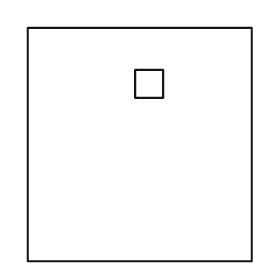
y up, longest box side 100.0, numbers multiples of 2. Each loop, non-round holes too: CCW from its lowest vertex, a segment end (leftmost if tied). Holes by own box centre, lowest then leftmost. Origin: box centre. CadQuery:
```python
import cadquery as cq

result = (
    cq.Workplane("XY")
    .moveTo(-48.0, -50.0)
    .lineTo(48.0, -50.0)
    .lineTo(48.0, 50.0)
    .lineTo(-48.0, 50.0)
    .close()
    .moveTo(-2.0, 20.0)
    .lineTo(10.0, 20.0)
    .lineTo(10.0, 32.0)
    .lineTo(-2.0, 32.0)
    .close()
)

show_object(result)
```